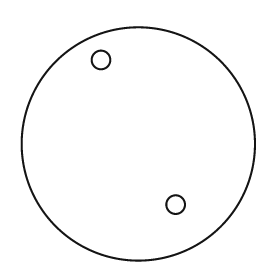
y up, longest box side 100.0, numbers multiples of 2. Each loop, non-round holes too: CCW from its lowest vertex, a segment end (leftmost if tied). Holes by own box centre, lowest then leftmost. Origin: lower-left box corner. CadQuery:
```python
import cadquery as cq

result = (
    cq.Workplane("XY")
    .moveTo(50.0, 50.0)
    .circle(50.0)
    .moveTo(66.0, 24.0)
    .circle(4.0)
    .moveTo(34.0, 86.0)
    .circle(4.0)
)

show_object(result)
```